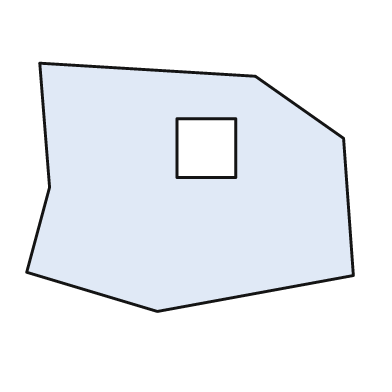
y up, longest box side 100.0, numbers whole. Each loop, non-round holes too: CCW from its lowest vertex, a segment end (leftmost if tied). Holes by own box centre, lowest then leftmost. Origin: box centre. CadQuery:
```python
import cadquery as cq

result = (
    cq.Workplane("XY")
    .moveTo(-10.0, -38.0)
    .lineTo(50.0, -27.0)
    .lineTo(47.0, 15.0)
    .lineTo(20.0, 34.0)
    .lineTo(-46.0, 38.0)
    .lineTo(-43.0, 0.0)
    .lineTo(-50.0, -26.0)
    .close()
    .moveTo(-4.0, 3.0)
    .lineTo(14.0, 3.0)
    .lineTo(14.0, 21.0)
    .lineTo(-4.0, 21.0)
    .close()
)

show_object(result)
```